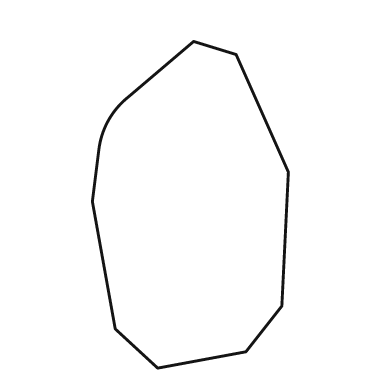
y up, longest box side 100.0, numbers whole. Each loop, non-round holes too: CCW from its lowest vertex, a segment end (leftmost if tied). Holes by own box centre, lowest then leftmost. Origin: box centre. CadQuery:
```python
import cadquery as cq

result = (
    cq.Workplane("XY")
    .moveTo(-10.0, -50.0)
    .lineTo(17.0, -45.0)
    .lineTo(28.0, -31.0)
    .lineTo(30.0, 10.0)
    .lineTo(14.0, 46.0)
    .lineTo(1.0, 50.0)
    .lineTo(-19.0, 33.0)
    .threePointArc((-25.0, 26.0), (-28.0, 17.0))
    .lineTo(-30.0, 1.0)
    .lineTo(-23.0, -38.0)
    .close()
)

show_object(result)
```